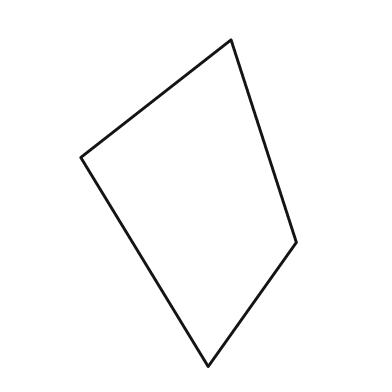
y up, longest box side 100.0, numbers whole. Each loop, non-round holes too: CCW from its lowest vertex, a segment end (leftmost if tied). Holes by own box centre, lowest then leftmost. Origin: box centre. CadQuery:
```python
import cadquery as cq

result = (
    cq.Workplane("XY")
    .moveTo(6.0, -50.0)
    .lineTo(33.0, -12.0)
    .lineTo(13.0, 50.0)
    .lineTo(-33.0, 14.0)
    .close()
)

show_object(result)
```